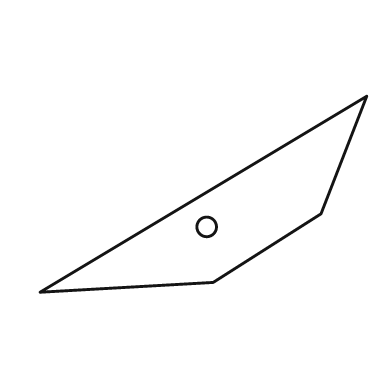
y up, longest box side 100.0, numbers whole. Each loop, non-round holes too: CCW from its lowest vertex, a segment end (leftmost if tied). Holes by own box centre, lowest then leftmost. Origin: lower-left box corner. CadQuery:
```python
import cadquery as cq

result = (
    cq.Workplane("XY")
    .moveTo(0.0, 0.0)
    .lineTo(53.0, 3.0)
    .lineTo(86.0, 24.0)
    .lineTo(100.0, 60.0)
    .close()
    .moveTo(51.0, 20.0)
    .circle(3.0)
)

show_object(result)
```